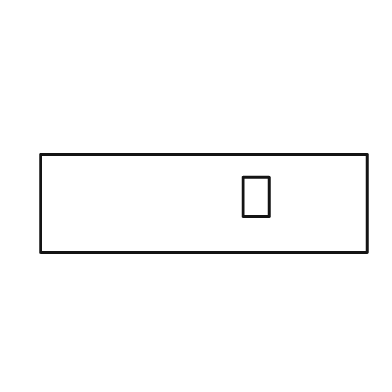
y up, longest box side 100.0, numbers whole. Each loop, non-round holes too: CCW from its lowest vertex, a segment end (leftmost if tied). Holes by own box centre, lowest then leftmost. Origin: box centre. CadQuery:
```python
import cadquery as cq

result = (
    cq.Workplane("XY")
    .moveTo(-50.0, -15.0)
    .lineTo(50.0, -15.0)
    .lineTo(50.0, 15.0)
    .lineTo(-50.0, 15.0)
    .close()
    .moveTo(12.0, -4.0)
    .lineTo(20.0, -4.0)
    .lineTo(20.0, 8.0)
    .lineTo(12.0, 8.0)
    .close()
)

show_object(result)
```